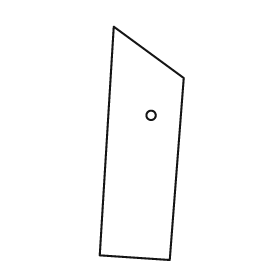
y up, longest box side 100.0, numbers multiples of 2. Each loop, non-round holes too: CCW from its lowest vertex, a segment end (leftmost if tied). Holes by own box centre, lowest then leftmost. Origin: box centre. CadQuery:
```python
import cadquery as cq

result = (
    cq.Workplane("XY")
    .moveTo(12.0, -50.0)
    .lineTo(18.0, 28.0)
    .lineTo(-12.0, 50.0)
    .lineTo(-18.0, -48.0)
    .close()
    .moveTo(4.0, 12.0)
    .circle(2.0)
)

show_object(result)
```